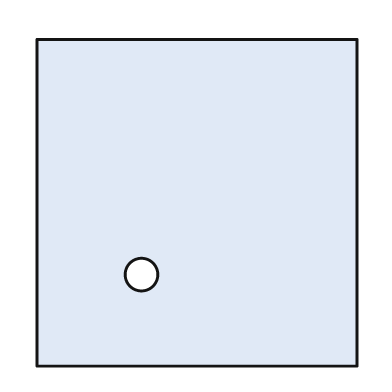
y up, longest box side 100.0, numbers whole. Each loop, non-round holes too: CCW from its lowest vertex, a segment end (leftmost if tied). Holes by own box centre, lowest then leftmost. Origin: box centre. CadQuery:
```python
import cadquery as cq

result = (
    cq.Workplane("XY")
    .moveTo(-49.0, -50.0)
    .lineTo(49.0, -50.0)
    .lineTo(49.0, 50.0)
    .lineTo(-49.0, 50.0)
    .close()
    .moveTo(-17.0, -22.0)
    .circle(5.0)
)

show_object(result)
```